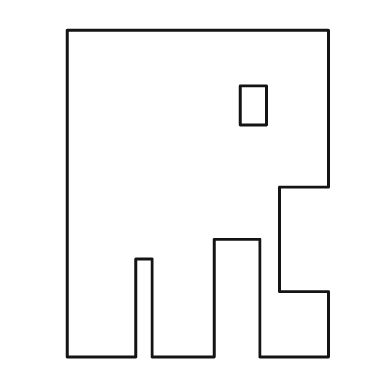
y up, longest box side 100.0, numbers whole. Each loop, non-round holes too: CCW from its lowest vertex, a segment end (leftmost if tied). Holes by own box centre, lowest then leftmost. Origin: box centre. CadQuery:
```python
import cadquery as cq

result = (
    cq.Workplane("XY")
    .moveTo(-40.0, -50.0)
    .lineTo(-19.0, -50.0)
    .lineTo(-19.0, -20.0)
    .lineTo(-14.0, -20.0)
    .lineTo(-14.0, -50.0)
    .lineTo(5.0, -50.0)
    .lineTo(5.0, -14.0)
    .lineTo(19.0, -14.0)
    .lineTo(19.0, -50.0)
    .lineTo(40.0, -50.0)
    .lineTo(40.0, -30.0)
    .lineTo(25.0, -30.0)
    .lineTo(25.0, 2.0)
    .lineTo(40.0, 2.0)
    .lineTo(40.0, 50.0)
    .lineTo(-40.0, 50.0)
    .close()
    .moveTo(13.0, 21.0)
    .lineTo(21.0, 21.0)
    .lineTo(21.0, 33.0)
    .lineTo(13.0, 33.0)
    .close()
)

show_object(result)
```